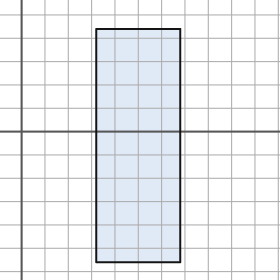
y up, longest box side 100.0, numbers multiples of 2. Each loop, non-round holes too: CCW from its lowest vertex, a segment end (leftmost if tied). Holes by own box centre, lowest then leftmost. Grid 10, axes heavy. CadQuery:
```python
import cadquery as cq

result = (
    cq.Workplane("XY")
    .moveTo(32.0, -56.0)
    .lineTo(68.0, -56.0)
    .lineTo(68.0, 44.0)
    .lineTo(32.0, 44.0)
    .close()
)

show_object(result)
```